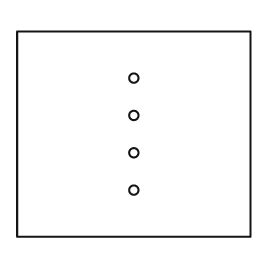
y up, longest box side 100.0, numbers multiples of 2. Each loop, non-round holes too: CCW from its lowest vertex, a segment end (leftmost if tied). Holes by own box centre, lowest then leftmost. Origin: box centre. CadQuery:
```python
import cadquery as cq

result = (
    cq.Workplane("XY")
    .moveTo(-50.0, -44.0)
    .lineTo(50.0, -44.0)
    .lineTo(50.0, 44.0)
    .lineTo(-50.0, 44.0)
    .close()
    .moveTo(0.0, -24.0)
    .circle(2.0)
    .moveTo(0.0, -8.0)
    .circle(2.0)
    .moveTo(0.0, 8.0)
    .circle(2.0)
    .moveTo(0.0, 24.0)
    .circle(2.0)
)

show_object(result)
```